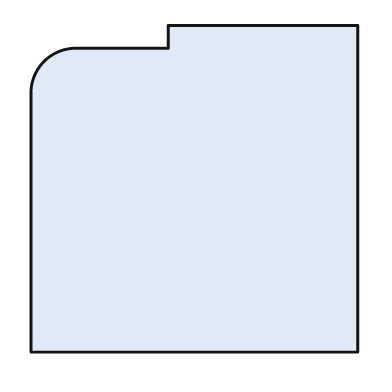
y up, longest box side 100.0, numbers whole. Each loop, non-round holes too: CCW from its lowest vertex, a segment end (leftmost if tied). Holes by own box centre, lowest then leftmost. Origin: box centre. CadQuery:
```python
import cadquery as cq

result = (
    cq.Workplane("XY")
    .moveTo(-50.0, -50.0)
    .lineTo(50.0, -50.0)
    .lineTo(50.0, 50.0)
    .lineTo(-8.0, 50.0)
    .lineTo(-8.0, 43.0)
    .lineTo(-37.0, 43.0)
    .threePointArc((-46.0, 39.0), (-50.0, 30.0))
    .close()
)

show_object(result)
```